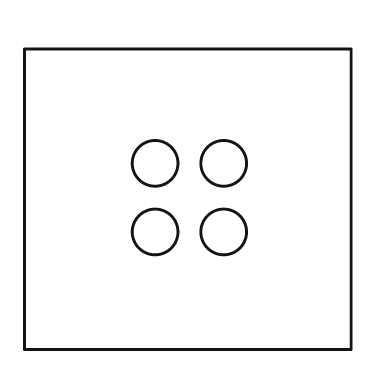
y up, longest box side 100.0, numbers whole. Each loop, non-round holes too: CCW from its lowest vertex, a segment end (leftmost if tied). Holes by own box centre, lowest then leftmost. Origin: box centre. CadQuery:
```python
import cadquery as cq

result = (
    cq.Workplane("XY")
    .moveTo(-50.0, -46.0)
    .lineTo(50.0, -46.0)
    .lineTo(50.0, 46.0)
    .lineTo(-50.0, 46.0)
    .close()
    .moveTo(-10.0, -10.0)
    .circle(7.0)
    .moveTo(11.0, -10.0)
    .circle(7.0)
    .moveTo(-10.0, 11.0)
    .circle(7.0)
    .moveTo(11.0, 11.0)
    .circle(7.0)
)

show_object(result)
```